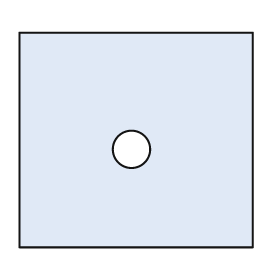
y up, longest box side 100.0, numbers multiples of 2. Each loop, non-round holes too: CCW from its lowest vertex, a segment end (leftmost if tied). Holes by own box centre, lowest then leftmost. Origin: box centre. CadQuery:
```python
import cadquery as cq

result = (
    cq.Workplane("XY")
    .moveTo(-50.0, -46.0)
    .lineTo(50.0, -46.0)
    .lineTo(50.0, 46.0)
    .lineTo(-50.0, 46.0)
    .close()
    .moveTo(-2.0, -4.0)
    .circle(8.0)
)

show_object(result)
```